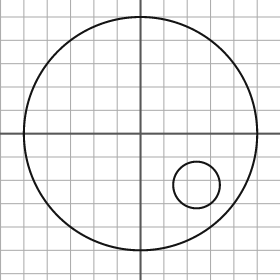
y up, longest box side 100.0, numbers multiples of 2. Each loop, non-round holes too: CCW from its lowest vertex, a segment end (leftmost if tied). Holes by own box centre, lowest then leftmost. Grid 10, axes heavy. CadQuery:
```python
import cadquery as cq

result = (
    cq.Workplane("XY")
    .moveTo(0.0, 0.0)
    .circle(50.0)
    .moveTo(24.0, -22.0)
    .circle(10.0)
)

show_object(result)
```